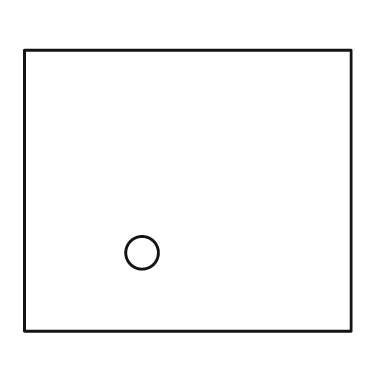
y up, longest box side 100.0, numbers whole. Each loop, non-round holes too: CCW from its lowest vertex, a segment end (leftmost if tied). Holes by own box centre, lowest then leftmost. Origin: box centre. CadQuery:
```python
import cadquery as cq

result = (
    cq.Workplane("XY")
    .moveTo(-50.0, -43.0)
    .lineTo(50.0, -43.0)
    .lineTo(50.0, 43.0)
    .lineTo(-50.0, 43.0)
    .close()
    .moveTo(-14.0, -19.0)
    .circle(5.0)
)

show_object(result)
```